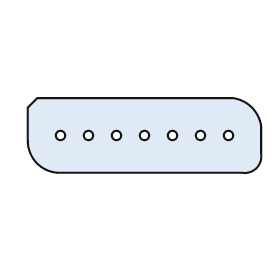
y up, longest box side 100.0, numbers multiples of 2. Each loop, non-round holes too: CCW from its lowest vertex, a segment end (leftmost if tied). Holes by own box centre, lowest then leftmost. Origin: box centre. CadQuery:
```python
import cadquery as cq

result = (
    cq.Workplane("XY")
    .moveTo(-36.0, -16.0)
    .lineTo(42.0, -16.0)
    .threePointArc((48.0, -14.0), (50.0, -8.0))
    .lineTo(50.0, 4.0)
    .threePointArc((46.0, 12.0), (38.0, 16.0))
    .lineTo(-46.0, 16.0)
    .lineTo(-50.0, 12.0)
    .lineTo(-50.0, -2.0)
    .threePointArc((-46.0, -12.0), (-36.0, -16.0))
    .close()
    .moveTo(-36.0, 0.0)
    .circle(2.0)
    .moveTo(-24.0, 0.0)
    .circle(2.0)
    .moveTo(-12.0, 0.0)
    .circle(2.0)
    .moveTo(0.0, 0.0)
    .circle(2.0)
    .moveTo(12.0, 0.0)
    .circle(2.0)
    .moveTo(24.0, 0.0)
    .circle(2.0)
    .moveTo(36.0, 0.0)
    .circle(2.0)
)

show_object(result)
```